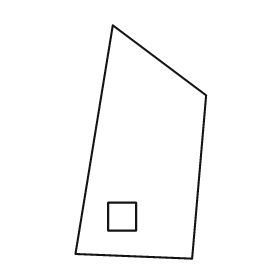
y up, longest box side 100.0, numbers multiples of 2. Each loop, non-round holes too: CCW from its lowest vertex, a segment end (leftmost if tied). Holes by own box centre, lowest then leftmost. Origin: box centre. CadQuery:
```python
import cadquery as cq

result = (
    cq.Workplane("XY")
    .moveTo(22.0, -50.0)
    .lineTo(28.0, 20.0)
    .lineTo(-12.0, 50.0)
    .lineTo(-28.0, -48.0)
    .close()
    .moveTo(-14.0, -38.0)
    .lineTo(-2.0, -38.0)
    .lineTo(-2.0, -26.0)
    .lineTo(-14.0, -26.0)
    .close()
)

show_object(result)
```